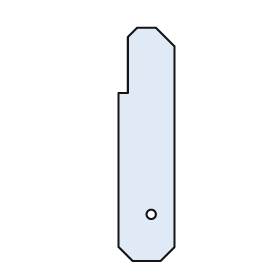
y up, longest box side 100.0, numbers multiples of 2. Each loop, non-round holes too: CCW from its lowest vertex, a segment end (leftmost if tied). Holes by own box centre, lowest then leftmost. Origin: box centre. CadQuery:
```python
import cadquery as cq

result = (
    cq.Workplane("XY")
    .moveTo(-6.0, -50.0)
    .lineTo(6.0, -50.0)
    .lineTo(12.0, -44.0)
    .lineTo(12.0, 42.0)
    .lineTo(4.0, 50.0)
    .lineTo(-4.0, 50.0)
    .lineTo(-8.0, 46.0)
    .lineTo(-8.0, 22.0)
    .lineTo(-12.0, 22.0)
    .lineTo(-12.0, -44.0)
    .close()
    .moveTo(2.0, -30.0)
    .circle(2.0)
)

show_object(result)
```